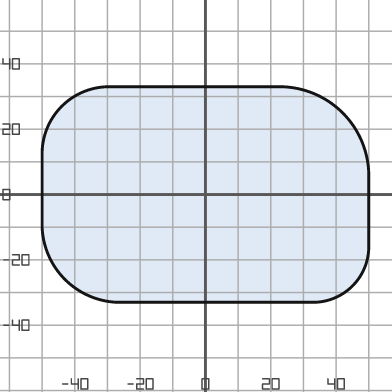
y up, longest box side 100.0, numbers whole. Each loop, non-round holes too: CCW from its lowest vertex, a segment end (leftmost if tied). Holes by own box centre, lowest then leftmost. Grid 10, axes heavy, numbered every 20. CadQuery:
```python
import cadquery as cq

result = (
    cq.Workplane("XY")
    .moveTo(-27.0, -33.0)
    .lineTo(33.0, -33.0)
    .threePointArc((45.0, -28.0), (50.0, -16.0))
    .lineTo(50.0, 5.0)
    .threePointArc((42.0, 25.0), (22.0, 33.0))
    .lineTo(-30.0, 33.0)
    .threePointArc((-44.0, 27.0), (-50.0, 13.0))
    .lineTo(-50.0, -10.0)
    .threePointArc((-43.0, -26.0), (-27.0, -33.0))
    .close()
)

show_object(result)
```